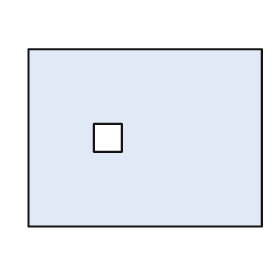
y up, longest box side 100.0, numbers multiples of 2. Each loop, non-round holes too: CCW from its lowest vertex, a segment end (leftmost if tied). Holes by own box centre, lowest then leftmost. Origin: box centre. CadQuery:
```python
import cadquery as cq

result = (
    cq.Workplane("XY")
    .moveTo(-50.0, -38.0)
    .lineTo(50.0, -38.0)
    .lineTo(50.0, 38.0)
    .lineTo(-50.0, 38.0)
    .close()
    .moveTo(-22.0, -6.0)
    .lineTo(-10.0, -6.0)
    .lineTo(-10.0, 6.0)
    .lineTo(-22.0, 6.0)
    .close()
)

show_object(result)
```